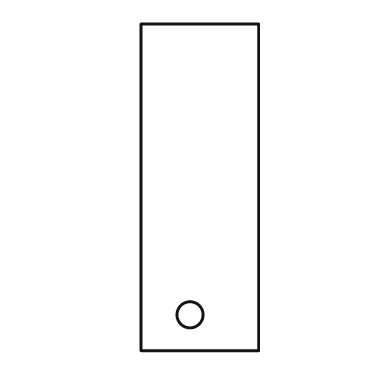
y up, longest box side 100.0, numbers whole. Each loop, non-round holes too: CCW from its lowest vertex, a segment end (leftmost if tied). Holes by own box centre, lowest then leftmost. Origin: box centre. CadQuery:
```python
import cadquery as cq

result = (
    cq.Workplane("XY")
    .moveTo(-18.0, -50.0)
    .lineTo(18.0, -50.0)
    .lineTo(18.0, 50.0)
    .lineTo(-18.0, 50.0)
    .close()
    .moveTo(-3.0, -39.0)
    .circle(4.0)
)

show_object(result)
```